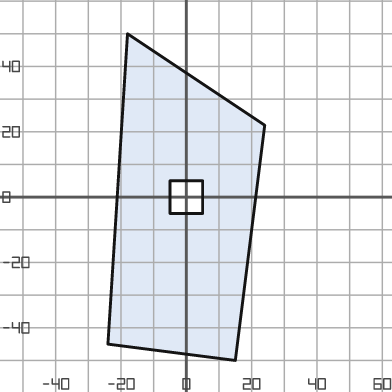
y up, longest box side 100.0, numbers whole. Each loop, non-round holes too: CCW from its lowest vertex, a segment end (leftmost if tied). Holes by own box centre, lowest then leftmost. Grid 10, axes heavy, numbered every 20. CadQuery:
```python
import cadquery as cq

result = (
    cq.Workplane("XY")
    .moveTo(15.0, -50.0)
    .lineTo(24.0, 22.0)
    .lineTo(-18.0, 50.0)
    .lineTo(-24.0, -45.0)
    .close()
    .moveTo(-5.0, -5.0)
    .lineTo(5.0, -5.0)
    .lineTo(5.0, 5.0)
    .lineTo(-5.0, 5.0)
    .close()
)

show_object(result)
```